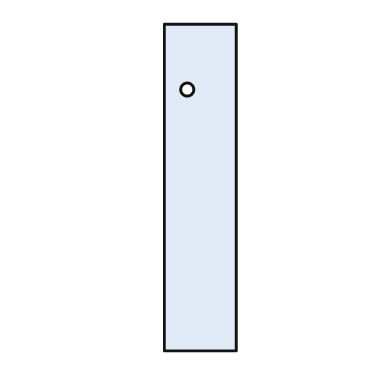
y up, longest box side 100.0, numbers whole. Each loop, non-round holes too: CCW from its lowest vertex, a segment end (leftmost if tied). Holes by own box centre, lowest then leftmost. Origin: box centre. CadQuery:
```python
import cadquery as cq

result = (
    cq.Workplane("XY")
    .moveTo(-11.0, -50.0)
    .lineTo(11.0, -50.0)
    .lineTo(11.0, 50.0)
    .lineTo(-11.0, 50.0)
    .close()
    .moveTo(-4.0, 30.0)
    .circle(2.0)
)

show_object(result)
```